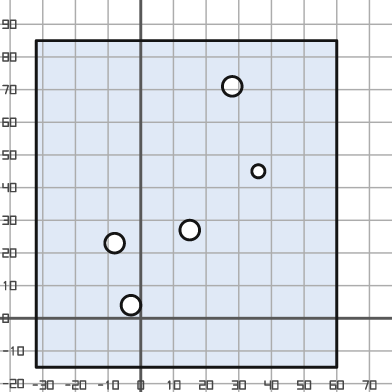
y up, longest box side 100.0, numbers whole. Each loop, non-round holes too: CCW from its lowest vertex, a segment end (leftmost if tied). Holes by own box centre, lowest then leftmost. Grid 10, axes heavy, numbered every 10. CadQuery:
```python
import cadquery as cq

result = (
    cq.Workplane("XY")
    .moveTo(-32.0, -15.0)
    .lineTo(60.0, -15.0)
    .lineTo(60.0, 85.0)
    .lineTo(-32.0, 85.0)
    .close()
    .moveTo(-3.0, 4.0)
    .circle(3.0)
    .moveTo(-8.0, 23.0)
    .circle(3.0)
    .moveTo(15.0, 27.0)
    .circle(3.0)
    .moveTo(36.0, 45.0)
    .circle(2.0)
    .moveTo(28.0, 71.0)
    .circle(3.0)
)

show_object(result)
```